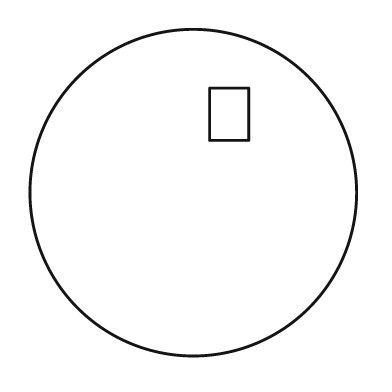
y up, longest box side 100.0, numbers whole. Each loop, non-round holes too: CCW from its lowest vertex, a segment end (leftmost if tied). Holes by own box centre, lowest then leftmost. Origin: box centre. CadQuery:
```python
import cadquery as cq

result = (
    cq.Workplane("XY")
    .moveTo(0.0, 0.0)
    .circle(50.0)
    .moveTo(5.0, 16.0)
    .lineTo(17.0, 16.0)
    .lineTo(17.0, 32.0)
    .lineTo(5.0, 32.0)
    .close()
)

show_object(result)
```